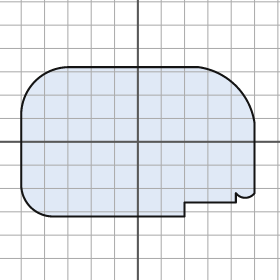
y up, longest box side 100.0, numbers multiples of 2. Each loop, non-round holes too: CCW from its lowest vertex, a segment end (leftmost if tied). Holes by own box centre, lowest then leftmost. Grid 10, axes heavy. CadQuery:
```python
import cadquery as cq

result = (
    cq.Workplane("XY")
    .moveTo(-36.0, -32.0)
    .lineTo(20.0, -32.0)
    .lineTo(20.0, -26.0)
    .lineTo(42.0, -26.0)
    .lineTo(42.0, -22.0)
    .threePointArc((46.0, -24.0), (50.0, -22.0))
    .lineTo(50.0, 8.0)
    .threePointArc((42.0, 24.0), (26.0, 32.0))
    .lineTo(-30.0, 32.0)
    .threePointArc((-44.0, 26.0), (-50.0, 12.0))
    .lineTo(-50.0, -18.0)
    .threePointArc((-46.0, -28.0), (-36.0, -32.0))
    .close()
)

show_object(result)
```